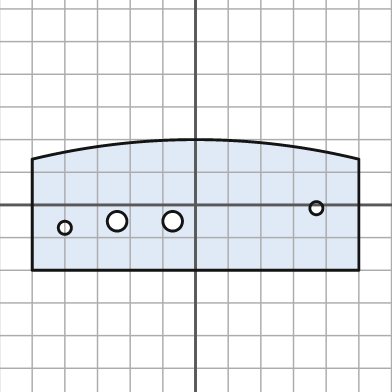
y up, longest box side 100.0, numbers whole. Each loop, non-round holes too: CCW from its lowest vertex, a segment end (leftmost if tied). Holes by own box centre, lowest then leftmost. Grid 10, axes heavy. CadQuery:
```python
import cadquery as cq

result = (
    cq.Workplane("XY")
    .moveTo(-50.0, -20.0)
    .lineTo(50.0, -20.0)
    .lineTo(50.0, 14.0)
    .threePointArc((0.0, 20.0), (-50.0, 14.0))
    .close()
    .moveTo(-40.0, -7.0)
    .circle(2.0)
    .moveTo(-24.0, -5.0)
    .circle(3.0)
    .moveTo(-7.0, -5.0)
    .circle(3.0)
    .moveTo(37.0, -1.0)
    .circle(2.0)
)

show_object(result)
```